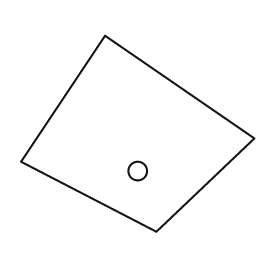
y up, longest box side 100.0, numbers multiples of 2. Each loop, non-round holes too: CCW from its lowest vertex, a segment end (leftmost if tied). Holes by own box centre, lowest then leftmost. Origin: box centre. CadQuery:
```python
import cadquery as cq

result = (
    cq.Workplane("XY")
    .moveTo(8.0, -42.0)
    .lineTo(50.0, -2.0)
    .lineTo(-14.0, 42.0)
    .lineTo(-50.0, -12.0)
    .close()
    .moveTo(0.0, -16.0)
    .circle(4.0)
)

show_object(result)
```